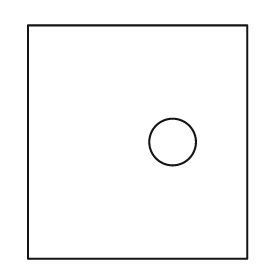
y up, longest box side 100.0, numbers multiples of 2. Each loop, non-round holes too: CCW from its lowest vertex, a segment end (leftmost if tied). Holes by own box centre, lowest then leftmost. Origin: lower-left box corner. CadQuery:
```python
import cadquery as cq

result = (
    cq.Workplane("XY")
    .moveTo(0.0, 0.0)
    .lineTo(94.0, 0.0)
    .lineTo(94.0, 100.0)
    .lineTo(0.0, 100.0)
    .close()
    .moveTo(62.0, 50.0)
    .circle(10.0)
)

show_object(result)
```